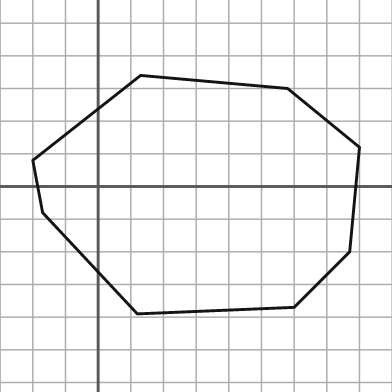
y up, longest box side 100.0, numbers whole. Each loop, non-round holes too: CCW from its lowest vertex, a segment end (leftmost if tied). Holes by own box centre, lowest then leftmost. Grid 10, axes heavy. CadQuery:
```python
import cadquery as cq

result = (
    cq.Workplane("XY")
    .moveTo(12.0, -39.0)
    .lineTo(60.0, -37.0)
    .lineTo(77.0, -20.0)
    .lineTo(80.0, 12.0)
    .lineTo(58.0, 30.0)
    .lineTo(13.0, 34.0)
    .lineTo(-20.0, 8.0)
    .lineTo(-17.0, -8.0)
    .close()
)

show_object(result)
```